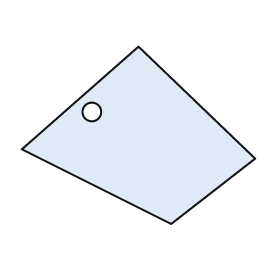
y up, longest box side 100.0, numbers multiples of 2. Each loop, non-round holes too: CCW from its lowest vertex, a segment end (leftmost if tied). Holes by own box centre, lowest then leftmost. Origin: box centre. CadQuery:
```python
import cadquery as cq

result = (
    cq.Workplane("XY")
    .moveTo(14.0, -38.0)
    .lineTo(50.0, -10.0)
    .lineTo(0.0, 38.0)
    .lineTo(-50.0, -6.0)
    .close()
    .moveTo(-20.0, 10.0)
    .circle(4.0)
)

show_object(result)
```